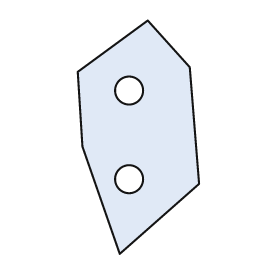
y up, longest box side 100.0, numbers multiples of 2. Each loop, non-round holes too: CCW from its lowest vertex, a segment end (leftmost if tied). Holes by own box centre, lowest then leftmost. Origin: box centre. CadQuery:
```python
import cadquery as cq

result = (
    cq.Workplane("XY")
    .moveTo(-8.0, -50.0)
    .lineTo(26.0, -20.0)
    .lineTo(22.0, 30.0)
    .lineTo(4.0, 50.0)
    .lineTo(-26.0, 28.0)
    .lineTo(-24.0, -4.0)
    .close()
    .moveTo(-4.0, -18.0)
    .circle(6.0)
    .moveTo(-4.0, 20.0)
    .circle(6.0)
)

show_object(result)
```